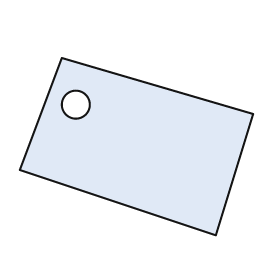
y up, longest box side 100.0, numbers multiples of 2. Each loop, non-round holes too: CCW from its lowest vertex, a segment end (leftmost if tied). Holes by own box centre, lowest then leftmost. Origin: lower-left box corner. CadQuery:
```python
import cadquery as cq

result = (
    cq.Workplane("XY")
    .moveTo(84.0, 0.0)
    .lineTo(100.0, 52.0)
    .lineTo(18.0, 76.0)
    .lineTo(0.0, 28.0)
    .close()
    .moveTo(24.0, 56.0)
    .circle(6.0)
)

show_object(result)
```